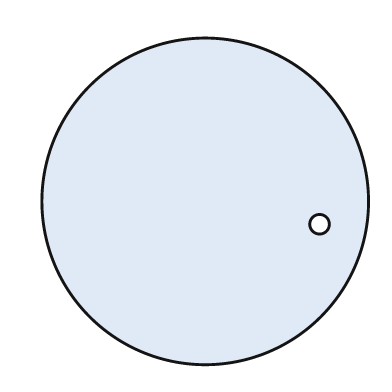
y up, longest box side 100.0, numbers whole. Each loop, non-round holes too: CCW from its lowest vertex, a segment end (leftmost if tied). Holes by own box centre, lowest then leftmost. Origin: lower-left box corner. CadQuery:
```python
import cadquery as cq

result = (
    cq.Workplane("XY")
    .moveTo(50.0, 50.0)
    .circle(50.0)
    .moveTo(85.0, 43.0)
    .circle(3.0)
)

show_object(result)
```